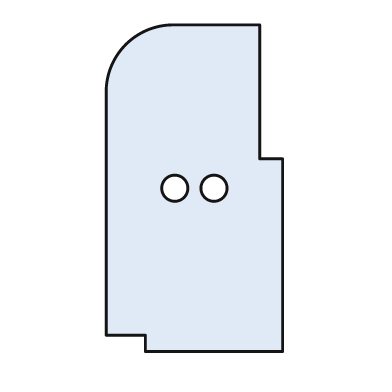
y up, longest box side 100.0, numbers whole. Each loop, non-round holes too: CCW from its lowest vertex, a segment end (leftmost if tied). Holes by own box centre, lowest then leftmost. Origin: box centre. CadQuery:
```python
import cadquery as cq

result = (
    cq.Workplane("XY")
    .moveTo(-15.0, -50.0)
    .lineTo(27.0, -50.0)
    .lineTo(27.0, 9.0)
    .lineTo(20.0, 9.0)
    .lineTo(20.0, 50.0)
    .lineTo(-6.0, 50.0)
    .threePointArc((-21.0, 44.0), (-27.0, 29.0))
    .lineTo(-27.0, -45.0)
    .lineTo(-15.0, -45.0)
    .close()
    .moveTo(-6.0, 0.0)
    .circle(4.0)
    .moveTo(6.0, 0.0)
    .circle(4.0)
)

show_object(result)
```